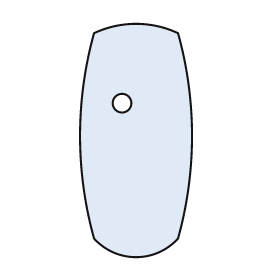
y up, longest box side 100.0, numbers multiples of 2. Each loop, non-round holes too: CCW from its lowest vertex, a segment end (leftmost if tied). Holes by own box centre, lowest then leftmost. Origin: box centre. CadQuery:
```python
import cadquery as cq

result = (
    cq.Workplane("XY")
    .moveTo(-18.0, -42.0)
    .threePointArc((0.0, -50.0), (18.0, -42.0))
    .threePointArc((24.0, 2.0), (18.0, 46.0))
    .threePointArc((0.0, 50.0), (-18.0, 46.0))
    .threePointArc((-24.0, 2.0), (-18.0, -42.0))
    .close()
    .moveTo(-6.0, 16.0)
    .circle(4.0)
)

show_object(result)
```